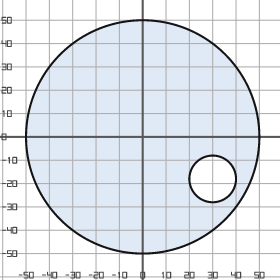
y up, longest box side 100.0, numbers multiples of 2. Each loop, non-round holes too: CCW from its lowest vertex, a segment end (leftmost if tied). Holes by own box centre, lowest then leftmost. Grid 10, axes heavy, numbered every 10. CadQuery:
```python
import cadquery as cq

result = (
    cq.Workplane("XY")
    .moveTo(0.0, 0.0)
    .circle(50.0)
    .moveTo(30.0, -18.0)
    .circle(10.0)
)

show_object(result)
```